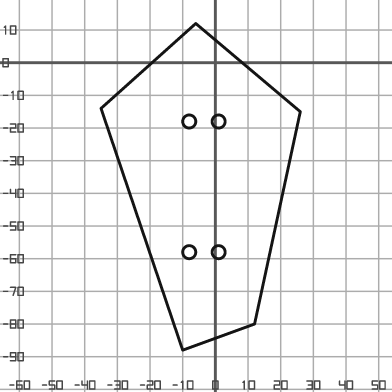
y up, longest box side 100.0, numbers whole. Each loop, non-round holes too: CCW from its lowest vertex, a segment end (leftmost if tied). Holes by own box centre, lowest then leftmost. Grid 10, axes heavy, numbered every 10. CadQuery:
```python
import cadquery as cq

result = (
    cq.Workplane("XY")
    .moveTo(-10.0, -88.0)
    .lineTo(12.0, -80.0)
    .lineTo(26.0, -15.0)
    .lineTo(-6.0, 12.0)
    .lineTo(-35.0, -14.0)
    .close()
    .moveTo(-8.0, -58.0)
    .circle(2.0)
    .moveTo(1.0, -58.0)
    .circle(2.0)
    .moveTo(-8.0, -18.0)
    .circle(2.0)
    .moveTo(1.0, -18.0)
    .circle(2.0)
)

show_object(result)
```